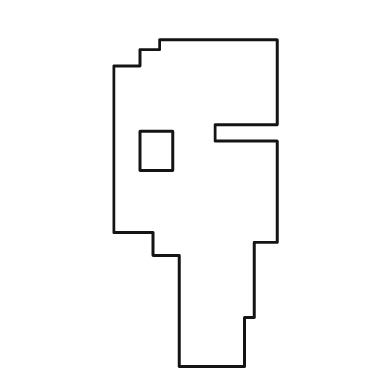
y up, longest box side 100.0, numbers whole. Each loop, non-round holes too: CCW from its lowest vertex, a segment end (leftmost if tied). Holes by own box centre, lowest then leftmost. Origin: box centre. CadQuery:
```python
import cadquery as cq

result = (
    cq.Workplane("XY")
    .moveTo(-5.0, -50.0)
    .lineTo(15.0, -50.0)
    .lineTo(15.0, -35.0)
    .lineTo(18.0, -35.0)
    .lineTo(18.0, -12.0)
    .lineTo(25.0, -12.0)
    .lineTo(25.0, 19.0)
    .lineTo(6.0, 19.0)
    .lineTo(6.0, 24.0)
    .lineTo(25.0, 24.0)
    .lineTo(25.0, 50.0)
    .lineTo(-11.0, 50.0)
    .lineTo(-11.0, 47.0)
    .lineTo(-17.0, 47.0)
    .lineTo(-17.0, 42.0)
    .lineTo(-25.0, 42.0)
    .lineTo(-25.0, -9.0)
    .lineTo(-13.0, -9.0)
    .lineTo(-13.0, -16.0)
    .lineTo(-5.0, -16.0)
    .close()
    .moveTo(-17.0, 10.0)
    .lineTo(-7.0, 10.0)
    .lineTo(-7.0, 22.0)
    .lineTo(-17.0, 22.0)
    .close()
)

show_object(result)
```